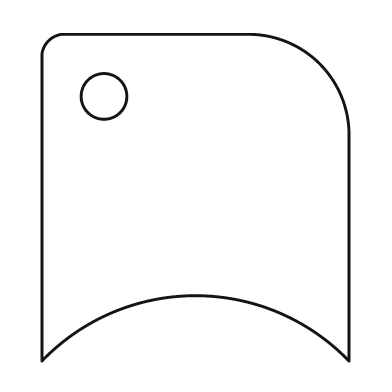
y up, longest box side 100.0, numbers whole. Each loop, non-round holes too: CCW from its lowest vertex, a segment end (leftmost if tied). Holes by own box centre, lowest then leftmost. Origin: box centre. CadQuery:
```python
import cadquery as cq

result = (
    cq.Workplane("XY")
    .moveTo(-47.0, -50.0)
    .threePointArc((0.0, -30.0), (47.0, -50.0))
    .lineTo(47.0, 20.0)
    .threePointArc((38.0, 41.0), (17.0, 50.0))
    .lineTo(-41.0, 50.0)
    .threePointArc((-45.0, 48.0), (-47.0, 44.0))
    .close()
    .moveTo(-28.0, 31.0)
    .circle(7.0)
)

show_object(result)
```